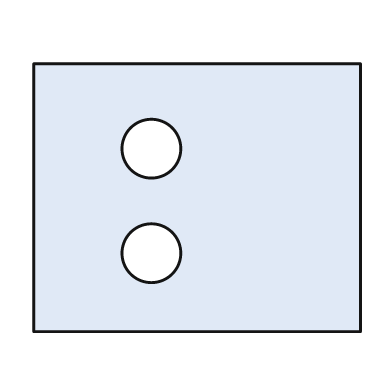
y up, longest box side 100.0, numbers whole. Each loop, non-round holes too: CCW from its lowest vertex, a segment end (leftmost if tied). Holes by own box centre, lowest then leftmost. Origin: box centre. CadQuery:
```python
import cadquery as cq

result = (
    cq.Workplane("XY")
    .moveTo(-50.0, -41.0)
    .lineTo(50.0, -41.0)
    .lineTo(50.0, 41.0)
    .lineTo(-50.0, 41.0)
    .close()
    .moveTo(-14.0, -17.0)
    .circle(9.0)
    .moveTo(-14.0, 15.0)
    .circle(9.0)
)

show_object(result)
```